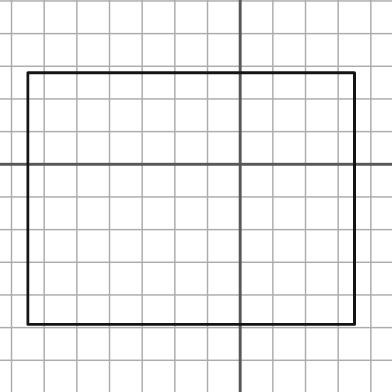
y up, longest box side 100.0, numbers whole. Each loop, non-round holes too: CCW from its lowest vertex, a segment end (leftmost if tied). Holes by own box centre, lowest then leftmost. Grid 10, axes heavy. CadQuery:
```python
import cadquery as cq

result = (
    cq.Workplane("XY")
    .moveTo(-65.0, -49.0)
    .lineTo(35.0, -49.0)
    .lineTo(35.0, 28.0)
    .lineTo(-65.0, 28.0)
    .close()
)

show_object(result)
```